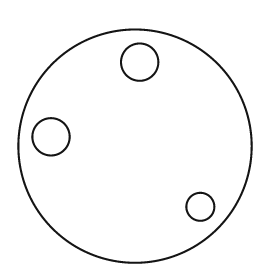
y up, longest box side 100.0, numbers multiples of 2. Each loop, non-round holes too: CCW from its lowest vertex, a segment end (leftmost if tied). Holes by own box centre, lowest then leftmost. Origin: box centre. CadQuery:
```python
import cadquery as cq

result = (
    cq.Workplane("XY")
    .moveTo(0.0, 0.0)
    .circle(50.0)
    .moveTo(28.0, -26.0)
    .circle(6.0)
    .moveTo(-36.0, 4.0)
    .circle(8.0)
    .moveTo(2.0, 36.0)
    .circle(8.0)
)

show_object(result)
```